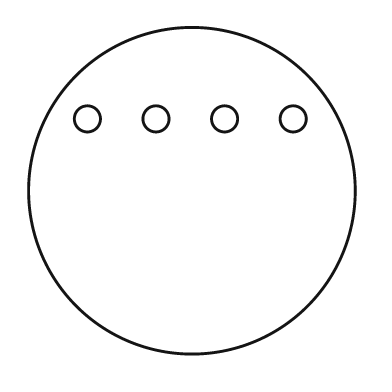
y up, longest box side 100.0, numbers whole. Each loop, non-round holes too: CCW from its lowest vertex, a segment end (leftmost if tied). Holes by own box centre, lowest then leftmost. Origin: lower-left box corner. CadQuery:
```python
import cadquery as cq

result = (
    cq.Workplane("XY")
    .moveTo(50.0, 50.0)
    .circle(50.0)
    .moveTo(18.0, 72.0)
    .circle(4.0)
    .moveTo(39.0, 72.0)
    .circle(4.0)
    .moveTo(60.0, 72.0)
    .circle(4.0)
    .moveTo(81.0, 72.0)
    .circle(4.0)
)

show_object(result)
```